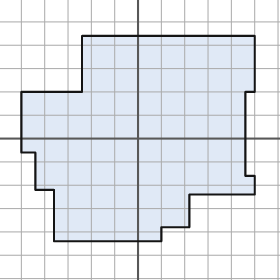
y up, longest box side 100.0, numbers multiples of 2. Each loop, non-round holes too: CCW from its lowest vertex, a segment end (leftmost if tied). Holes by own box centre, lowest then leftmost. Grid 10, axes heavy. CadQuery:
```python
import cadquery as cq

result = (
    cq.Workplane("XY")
    .moveTo(-36.0, -44.0)
    .lineTo(10.0, -44.0)
    .lineTo(10.0, -38.0)
    .lineTo(22.0, -38.0)
    .lineTo(22.0, -24.0)
    .lineTo(50.0, -24.0)
    .lineTo(50.0, -16.0)
    .lineTo(46.0, -16.0)
    .lineTo(46.0, 20.0)
    .lineTo(50.0, 20.0)
    .lineTo(50.0, 44.0)
    .lineTo(-24.0, 44.0)
    .lineTo(-24.0, 20.0)
    .lineTo(-50.0, 20.0)
    .lineTo(-50.0, -6.0)
    .lineTo(-44.0, -6.0)
    .lineTo(-44.0, -22.0)
    .lineTo(-36.0, -22.0)
    .close()
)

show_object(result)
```